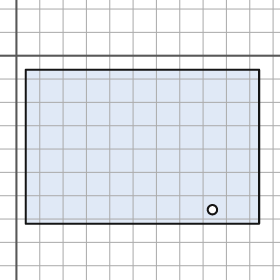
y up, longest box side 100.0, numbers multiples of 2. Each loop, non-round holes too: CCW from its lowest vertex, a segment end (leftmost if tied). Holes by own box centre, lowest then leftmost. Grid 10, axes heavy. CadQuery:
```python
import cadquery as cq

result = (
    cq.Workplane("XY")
    .moveTo(4.0, -72.0)
    .lineTo(104.0, -72.0)
    .lineTo(104.0, -6.0)
    .lineTo(4.0, -6.0)
    .close()
    .moveTo(84.0, -66.0)
    .circle(2.0)
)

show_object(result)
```